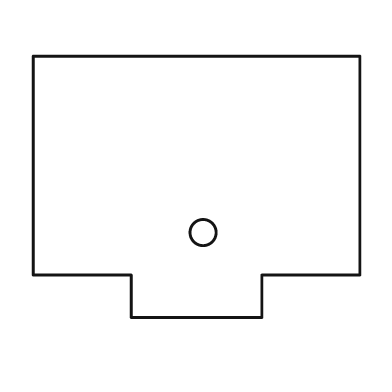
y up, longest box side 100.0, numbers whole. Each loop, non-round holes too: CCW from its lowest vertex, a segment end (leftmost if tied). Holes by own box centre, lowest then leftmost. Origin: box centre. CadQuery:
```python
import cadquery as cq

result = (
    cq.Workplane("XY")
    .moveTo(-20.0, -40.0)
    .lineTo(20.0, -40.0)
    .lineTo(20.0, -27.0)
    .lineTo(50.0, -27.0)
    .lineTo(50.0, 40.0)
    .lineTo(-50.0, 40.0)
    .lineTo(-50.0, -27.0)
    .lineTo(-20.0, -27.0)
    .close()
    .moveTo(2.0, -14.0)
    .circle(4.0)
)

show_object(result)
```